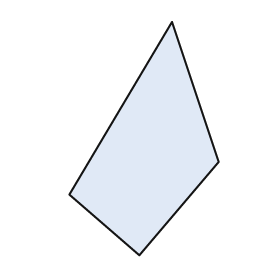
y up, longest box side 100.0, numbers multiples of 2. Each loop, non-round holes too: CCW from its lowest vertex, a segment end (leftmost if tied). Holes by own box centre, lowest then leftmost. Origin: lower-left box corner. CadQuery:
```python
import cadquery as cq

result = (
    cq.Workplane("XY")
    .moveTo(30.0, 0.0)
    .lineTo(64.0, 40.0)
    .lineTo(44.0, 100.0)
    .lineTo(0.0, 26.0)
    .close()
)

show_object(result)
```